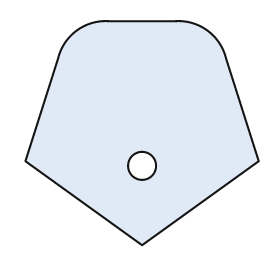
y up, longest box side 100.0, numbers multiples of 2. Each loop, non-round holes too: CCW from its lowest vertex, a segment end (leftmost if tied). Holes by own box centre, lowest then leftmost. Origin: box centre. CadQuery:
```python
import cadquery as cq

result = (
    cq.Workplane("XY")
    .moveTo(0.0, -48.0)
    .lineTo(50.0, -12.0)
    .lineTo(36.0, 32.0)
    .threePointArc((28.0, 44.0), (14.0, 48.0))
    .lineTo(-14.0, 48.0)
    .threePointArc((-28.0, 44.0), (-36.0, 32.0))
    .lineTo(-50.0, -12.0)
    .close()
    .moveTo(0.0, -14.0)
    .circle(6.0)
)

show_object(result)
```